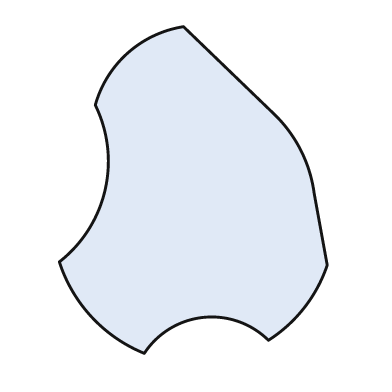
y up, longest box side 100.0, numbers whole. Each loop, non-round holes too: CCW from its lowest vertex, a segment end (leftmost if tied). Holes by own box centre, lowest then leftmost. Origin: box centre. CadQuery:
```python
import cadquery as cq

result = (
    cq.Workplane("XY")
    .moveTo(-15.0, -50.0)
    .threePointArc((3.0, -39.0), (23.0, -46.0))
    .threePointArc((34.0, -36.0), (41.0, -23.0))
    .lineTo(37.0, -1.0)
    .threePointArc((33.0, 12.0), (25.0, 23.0))
    .lineTo(-3.0, 50.0)
    .threePointArc((-20.0, 42.0), (-30.0, 26.0))
    .threePointArc((-27.0, 0.0), (-41.0, -22.0))
    .threePointArc((-31.0, -39.0), (-15.0, -50.0))
    .close()
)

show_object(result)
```